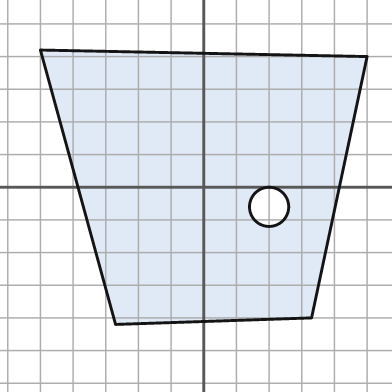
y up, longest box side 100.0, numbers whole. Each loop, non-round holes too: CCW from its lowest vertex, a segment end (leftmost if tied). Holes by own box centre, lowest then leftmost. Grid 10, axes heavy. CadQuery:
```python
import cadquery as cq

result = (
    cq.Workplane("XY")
    .moveTo(-27.0, -42.0)
    .lineTo(33.0, -40.0)
    .lineTo(50.0, 40.0)
    .lineTo(-50.0, 42.0)
    .close()
    .moveTo(20.0, -6.0)
    .circle(6.0)
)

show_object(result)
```